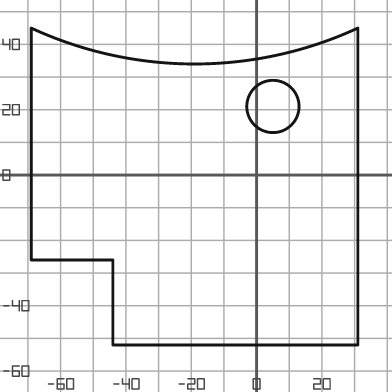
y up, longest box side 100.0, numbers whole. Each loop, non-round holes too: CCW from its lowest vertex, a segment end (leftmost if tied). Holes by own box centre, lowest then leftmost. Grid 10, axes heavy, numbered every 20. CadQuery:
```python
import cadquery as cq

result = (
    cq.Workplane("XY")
    .moveTo(-44.0, -52.0)
    .lineTo(31.0, -52.0)
    .lineTo(31.0, 45.0)
    .threePointArc((-19.0, 34.0), (-69.0, 45.0))
    .lineTo(-69.0, -26.0)
    .lineTo(-44.0, -26.0)
    .close()
    .moveTo(5.0, 21.0)
    .circle(8.0)
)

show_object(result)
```